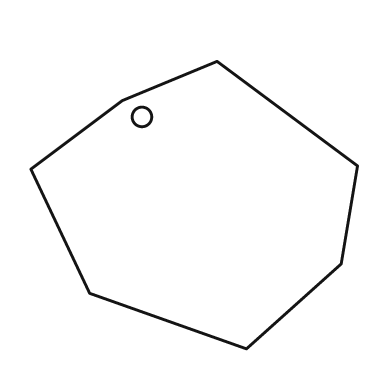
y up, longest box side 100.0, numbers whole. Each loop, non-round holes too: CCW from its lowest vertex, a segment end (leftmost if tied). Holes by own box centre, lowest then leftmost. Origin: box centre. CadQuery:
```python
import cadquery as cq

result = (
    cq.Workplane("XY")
    .moveTo(16.0, -44.0)
    .lineTo(45.0, -18.0)
    .lineTo(50.0, 12.0)
    .lineTo(7.0, 44.0)
    .lineTo(-22.0, 32.0)
    .lineTo(-50.0, 11.0)
    .lineTo(-32.0, -27.0)
    .close()
    .moveTo(-16.0, 27.0)
    .circle(3.0)
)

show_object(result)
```